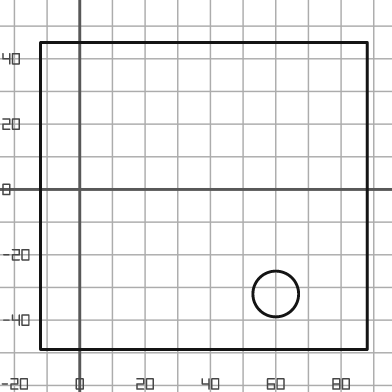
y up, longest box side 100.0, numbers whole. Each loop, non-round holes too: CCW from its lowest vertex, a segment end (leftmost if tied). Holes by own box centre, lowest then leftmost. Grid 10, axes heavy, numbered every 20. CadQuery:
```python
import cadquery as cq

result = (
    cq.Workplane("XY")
    .moveTo(-12.0, -49.0)
    .lineTo(88.0, -49.0)
    .lineTo(88.0, 45.0)
    .lineTo(-12.0, 45.0)
    .close()
    .moveTo(60.0, -32.0)
    .circle(7.0)
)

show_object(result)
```